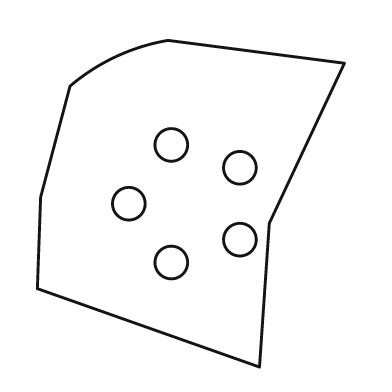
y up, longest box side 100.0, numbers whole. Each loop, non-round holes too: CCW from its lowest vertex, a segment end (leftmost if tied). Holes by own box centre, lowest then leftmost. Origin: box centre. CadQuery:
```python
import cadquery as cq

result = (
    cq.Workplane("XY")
    .moveTo(21.0, -50.0)
    .lineTo(24.0, -6.0)
    .lineTo(47.0, 43.0)
    .lineTo(-7.0, 50.0)
    .threePointArc((-23.0, 45.0), (-37.0, 36.0))
    .lineTo(-46.0, 2.0)
    .lineTo(-47.0, -26.0)
    .close()
    .moveTo(-6.0, -18.0)
    .circle(5.0)
    .moveTo(15.0, -11.0)
    .circle(5.0)
    .moveTo(-19.0, 0.0)
    .circle(5.0)
    .moveTo(15.0, 11.0)
    .circle(5.0)
    .moveTo(-6.0, 18.0)
    .circle(5.0)
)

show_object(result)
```